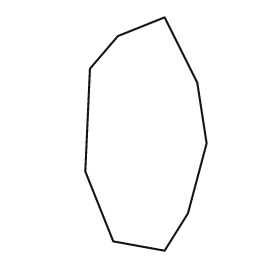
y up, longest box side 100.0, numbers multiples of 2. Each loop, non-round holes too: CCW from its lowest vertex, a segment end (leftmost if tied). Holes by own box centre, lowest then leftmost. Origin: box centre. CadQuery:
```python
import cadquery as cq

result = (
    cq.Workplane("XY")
    .moveTo(8.0, -50.0)
    .lineTo(18.0, -34.0)
    .lineTo(26.0, -4.0)
    .lineTo(22.0, 22.0)
    .lineTo(8.0, 50.0)
    .lineTo(-12.0, 42.0)
    .lineTo(-24.0, 28.0)
    .lineTo(-26.0, -16.0)
    .lineTo(-14.0, -46.0)
    .close()
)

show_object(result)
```